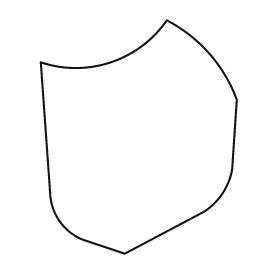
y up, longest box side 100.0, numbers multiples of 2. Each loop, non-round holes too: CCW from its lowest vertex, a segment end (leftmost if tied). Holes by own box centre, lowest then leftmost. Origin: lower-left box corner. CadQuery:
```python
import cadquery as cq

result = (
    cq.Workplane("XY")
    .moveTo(36.0, 0.0)
    .lineTo(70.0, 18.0)
    .threePointArc((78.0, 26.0), (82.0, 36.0))
    .lineTo(84.0, 66.0)
    .threePointArc((72.0, 86.0), (54.0, 100.0))
    .threePointArc((30.0, 82.0), (0.0, 82.0))
    .lineTo(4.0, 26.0)
    .threePointArc((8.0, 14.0), (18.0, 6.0))
    .close()
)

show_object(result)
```